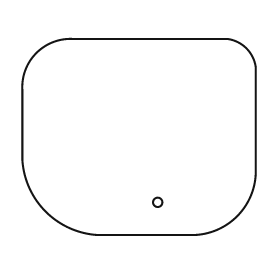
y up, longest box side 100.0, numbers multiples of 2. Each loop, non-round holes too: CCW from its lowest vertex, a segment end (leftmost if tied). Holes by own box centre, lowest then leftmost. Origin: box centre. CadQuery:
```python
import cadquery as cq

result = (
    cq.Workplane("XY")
    .moveTo(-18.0, -42.0)
    .lineTo(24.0, -42.0)
    .threePointArc((42.0, -34.0), (50.0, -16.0))
    .lineTo(50.0, 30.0)
    .threePointArc((46.0, 38.0), (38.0, 42.0))
    .lineTo(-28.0, 42.0)
    .threePointArc((-44.0, 36.0), (-50.0, 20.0))
    .lineTo(-50.0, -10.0)
    .threePointArc((-40.0, -32.0), (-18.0, -42.0))
    .close()
    .moveTo(8.0, -28.0)
    .circle(2.0)
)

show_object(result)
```